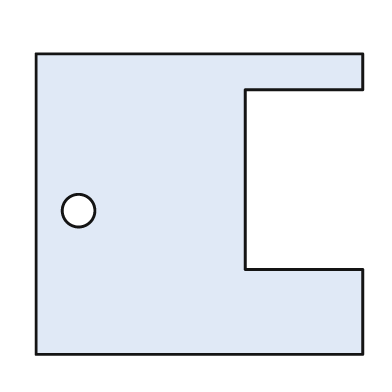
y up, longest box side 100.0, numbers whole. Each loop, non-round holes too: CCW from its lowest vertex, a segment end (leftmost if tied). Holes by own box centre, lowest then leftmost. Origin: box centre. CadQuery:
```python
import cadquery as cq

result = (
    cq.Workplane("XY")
    .moveTo(-50.0, -46.0)
    .lineTo(50.0, -46.0)
    .lineTo(50.0, -20.0)
    .lineTo(14.0, -20.0)
    .lineTo(14.0, 35.0)
    .lineTo(50.0, 35.0)
    .lineTo(50.0, 46.0)
    .lineTo(-50.0, 46.0)
    .close()
    .moveTo(-37.0, -2.0)
    .circle(5.0)
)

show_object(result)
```